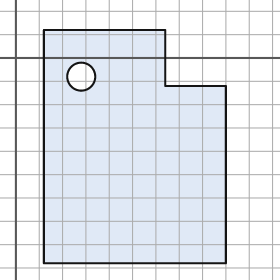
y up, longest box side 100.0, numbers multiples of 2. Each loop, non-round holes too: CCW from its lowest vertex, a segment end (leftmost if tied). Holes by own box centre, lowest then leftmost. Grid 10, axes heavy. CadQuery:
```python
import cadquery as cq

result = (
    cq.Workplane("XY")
    .moveTo(12.0, -88.0)
    .lineTo(90.0, -88.0)
    .lineTo(90.0, -12.0)
    .lineTo(64.0, -12.0)
    .lineTo(64.0, 12.0)
    .lineTo(12.0, 12.0)
    .close()
    .moveTo(28.0, -8.0)
    .circle(6.0)
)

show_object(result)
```